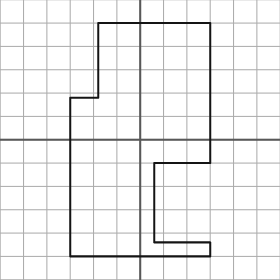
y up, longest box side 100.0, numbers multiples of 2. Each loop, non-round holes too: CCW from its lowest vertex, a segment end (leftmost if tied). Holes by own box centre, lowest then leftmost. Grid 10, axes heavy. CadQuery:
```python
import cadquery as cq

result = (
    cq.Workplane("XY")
    .moveTo(-30.0, -50.0)
    .lineTo(30.0, -50.0)
    .lineTo(30.0, -44.0)
    .lineTo(6.0, -44.0)
    .lineTo(6.0, -10.0)
    .lineTo(30.0, -10.0)
    .lineTo(30.0, 50.0)
    .lineTo(-18.0, 50.0)
    .lineTo(-18.0, 18.0)
    .lineTo(-30.0, 18.0)
    .close()
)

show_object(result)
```